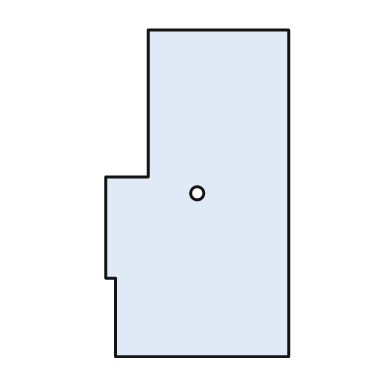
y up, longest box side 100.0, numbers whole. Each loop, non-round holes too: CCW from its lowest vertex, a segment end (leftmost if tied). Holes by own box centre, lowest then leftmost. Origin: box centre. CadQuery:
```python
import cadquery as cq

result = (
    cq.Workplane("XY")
    .moveTo(-25.0, -50.0)
    .lineTo(28.0, -50.0)
    .lineTo(28.0, 50.0)
    .lineTo(-15.0, 50.0)
    .lineTo(-15.0, 5.0)
    .lineTo(-28.0, 5.0)
    .lineTo(-28.0, -26.0)
    .lineTo(-25.0, -26.0)
    .close()
    .moveTo(0.0, 0.0)
    .circle(2.0)
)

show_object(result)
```